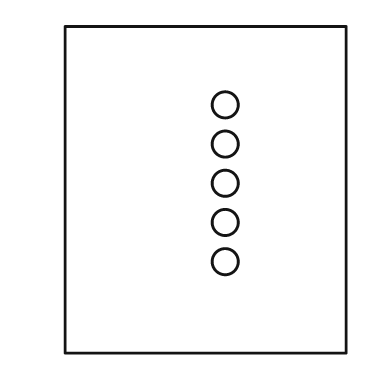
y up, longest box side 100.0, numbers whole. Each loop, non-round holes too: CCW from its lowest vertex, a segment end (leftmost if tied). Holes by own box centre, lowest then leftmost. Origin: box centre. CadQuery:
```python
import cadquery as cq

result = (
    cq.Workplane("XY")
    .moveTo(-43.0, -50.0)
    .lineTo(43.0, -50.0)
    .lineTo(43.0, 50.0)
    .lineTo(-43.0, 50.0)
    .close()
    .moveTo(6.0, -22.0)
    .circle(4.0)
    .moveTo(6.0, -10.0)
    .circle(4.0)
    .moveTo(6.0, 2.0)
    .circle(4.0)
    .moveTo(6.0, 14.0)
    .circle(4.0)
    .moveTo(6.0, 26.0)
    .circle(4.0)
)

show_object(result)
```